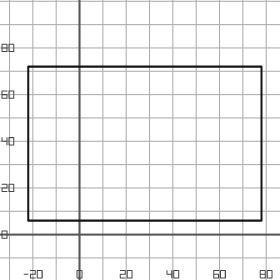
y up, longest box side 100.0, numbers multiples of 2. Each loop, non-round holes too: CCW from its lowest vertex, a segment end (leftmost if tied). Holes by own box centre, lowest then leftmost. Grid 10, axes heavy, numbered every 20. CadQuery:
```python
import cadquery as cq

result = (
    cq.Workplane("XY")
    .moveTo(-22.0, 6.0)
    .lineTo(78.0, 6.0)
    .lineTo(78.0, 72.0)
    .lineTo(-22.0, 72.0)
    .close()
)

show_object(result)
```